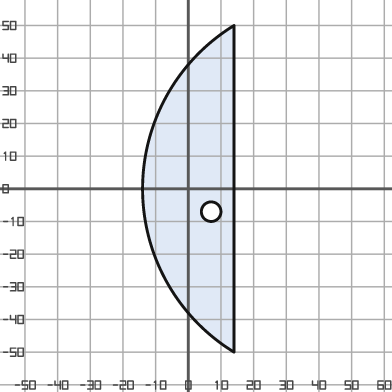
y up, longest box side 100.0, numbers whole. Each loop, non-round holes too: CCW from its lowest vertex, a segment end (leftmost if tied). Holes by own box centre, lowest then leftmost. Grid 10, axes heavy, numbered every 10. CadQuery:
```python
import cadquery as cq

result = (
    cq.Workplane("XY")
    .moveTo(14.0, -50.0)
    .lineTo(14.0, 50.0)
    .threePointArc((-14.0, 0.0), (14.0, -50.0))
    .close()
    .moveTo(7.0, -7.0)
    .circle(3.0)
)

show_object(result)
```